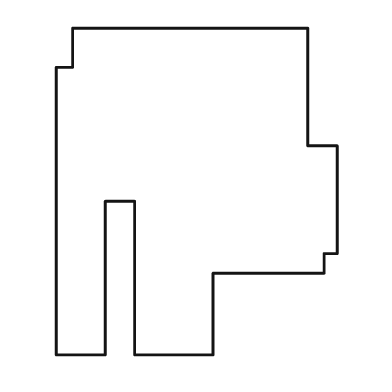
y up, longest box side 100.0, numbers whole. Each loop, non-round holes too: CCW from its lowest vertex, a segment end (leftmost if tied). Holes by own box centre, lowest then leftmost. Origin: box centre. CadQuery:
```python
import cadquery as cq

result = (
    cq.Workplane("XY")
    .moveTo(-43.0, -50.0)
    .lineTo(-28.0, -50.0)
    .lineTo(-28.0, -3.0)
    .lineTo(-19.0, -3.0)
    .lineTo(-19.0, -50.0)
    .lineTo(5.0, -50.0)
    .lineTo(5.0, -25.0)
    .lineTo(39.0, -25.0)
    .lineTo(39.0, -19.0)
    .lineTo(43.0, -19.0)
    .lineTo(43.0, 14.0)
    .lineTo(34.0, 14.0)
    .lineTo(34.0, 50.0)
    .lineTo(-38.0, 50.0)
    .lineTo(-38.0, 38.0)
    .lineTo(-43.0, 38.0)
    .close()
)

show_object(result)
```